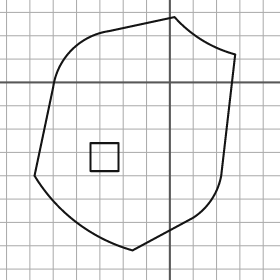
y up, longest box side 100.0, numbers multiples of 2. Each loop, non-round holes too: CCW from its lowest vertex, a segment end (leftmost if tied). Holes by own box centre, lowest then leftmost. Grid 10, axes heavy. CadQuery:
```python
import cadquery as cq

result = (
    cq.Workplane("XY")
    .moveTo(-16.0, -72.0)
    .lineTo(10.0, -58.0)
    .threePointArc((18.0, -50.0), (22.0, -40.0))
    .lineTo(28.0, 12.0)
    .threePointArc((14.0, 18.0), (2.0, 28.0))
    .lineTo(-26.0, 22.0)
    .threePointArc((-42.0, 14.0), (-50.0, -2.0))
    .lineTo(-58.0, -40.0)
    .threePointArc((-40.0, -60.0), (-16.0, -72.0))
    .close()
    .moveTo(-34.0, -38.0)
    .lineTo(-22.0, -38.0)
    .lineTo(-22.0, -26.0)
    .lineTo(-34.0, -26.0)
    .close()
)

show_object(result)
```